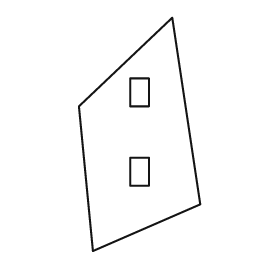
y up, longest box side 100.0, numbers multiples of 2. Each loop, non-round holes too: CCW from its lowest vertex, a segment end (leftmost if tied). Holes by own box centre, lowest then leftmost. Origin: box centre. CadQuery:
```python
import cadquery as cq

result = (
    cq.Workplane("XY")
    .moveTo(-20.0, -50.0)
    .lineTo(26.0, -30.0)
    .lineTo(14.0, 50.0)
    .lineTo(-26.0, 12.0)
    .close()
    .moveTo(-4.0, -22.0)
    .lineTo(4.0, -22.0)
    .lineTo(4.0, -10.0)
    .lineTo(-4.0, -10.0)
    .close()
    .moveTo(-4.0, 12.0)
    .lineTo(4.0, 12.0)
    .lineTo(4.0, 24.0)
    .lineTo(-4.0, 24.0)
    .close()
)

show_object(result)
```